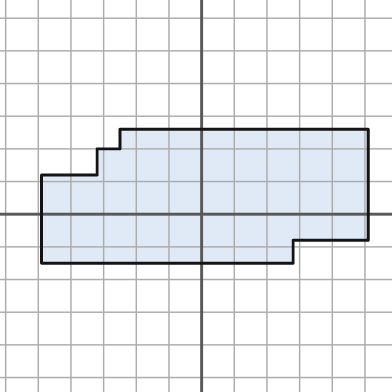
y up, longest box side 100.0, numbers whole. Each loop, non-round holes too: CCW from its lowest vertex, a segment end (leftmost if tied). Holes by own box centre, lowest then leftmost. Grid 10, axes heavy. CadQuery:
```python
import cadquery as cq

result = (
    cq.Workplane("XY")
    .moveTo(-49.0, -15.0)
    .lineTo(28.0, -15.0)
    .lineTo(28.0, -8.0)
    .lineTo(51.0, -8.0)
    .lineTo(51.0, 26.0)
    .lineTo(-25.0, 26.0)
    .lineTo(-25.0, 20.0)
    .lineTo(-32.0, 20.0)
    .lineTo(-32.0, 12.0)
    .lineTo(-49.0, 12.0)
    .close()
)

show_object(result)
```